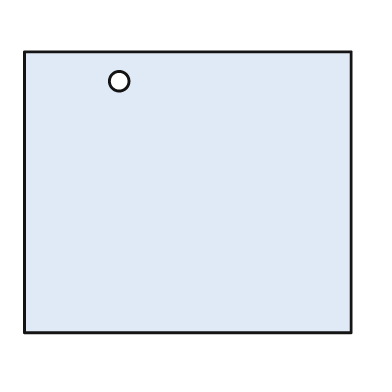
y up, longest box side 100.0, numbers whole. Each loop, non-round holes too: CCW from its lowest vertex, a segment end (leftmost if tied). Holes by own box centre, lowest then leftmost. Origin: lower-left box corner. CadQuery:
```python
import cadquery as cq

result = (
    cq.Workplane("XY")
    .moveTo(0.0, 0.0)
    .lineTo(100.0, 0.0)
    .lineTo(100.0, 86.0)
    .lineTo(0.0, 86.0)
    .close()
    .moveTo(29.0, 77.0)
    .circle(3.0)
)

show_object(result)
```